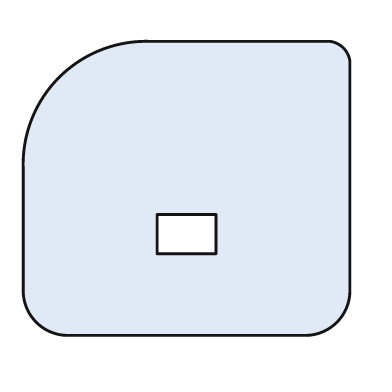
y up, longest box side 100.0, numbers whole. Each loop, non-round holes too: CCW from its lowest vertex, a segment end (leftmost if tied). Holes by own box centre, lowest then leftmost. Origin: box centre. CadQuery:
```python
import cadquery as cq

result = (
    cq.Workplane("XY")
    .moveTo(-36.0, -45.0)
    .lineTo(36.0, -45.0)
    .threePointArc((46.0, -41.0), (50.0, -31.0))
    .lineTo(50.0, 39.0)
    .threePointArc((48.0, 43.0), (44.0, 45.0))
    .lineTo(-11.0, 45.0)
    .threePointArc((-39.0, 34.0), (-50.0, 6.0))
    .lineTo(-50.0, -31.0)
    .threePointArc((-46.0, -41.0), (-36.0, -45.0))
    .close()
    .moveTo(-9.0, -20.0)
    .lineTo(9.0, -20.0)
    .lineTo(9.0, -8.0)
    .lineTo(-9.0, -8.0)
    .close()
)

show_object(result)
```